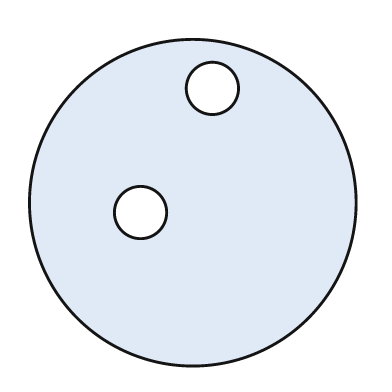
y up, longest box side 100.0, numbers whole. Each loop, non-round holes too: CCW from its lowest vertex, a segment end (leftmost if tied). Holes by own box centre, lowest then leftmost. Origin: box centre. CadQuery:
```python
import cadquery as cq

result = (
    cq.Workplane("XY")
    .moveTo(0.0, 0.0)
    .circle(50.0)
    .moveTo(-16.0, -3.0)
    .circle(8.0)
    .moveTo(6.0, 35.0)
    .circle(8.0)
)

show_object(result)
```